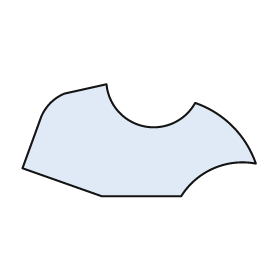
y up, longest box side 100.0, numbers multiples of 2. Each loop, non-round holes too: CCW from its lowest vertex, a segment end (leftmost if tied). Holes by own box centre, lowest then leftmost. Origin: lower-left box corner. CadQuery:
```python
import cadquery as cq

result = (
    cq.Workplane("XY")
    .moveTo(34.0, 0.0)
    .lineTo(68.0, 0.0)
    .threePointArc((82.0, 12.0), (100.0, 14.0))
    .threePointArc((90.0, 30.0), (74.0, 40.0))
    .threePointArc((52.0, 30.0), (36.0, 48.0))
    .lineTo(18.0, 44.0)
    .threePointArc((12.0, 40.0), (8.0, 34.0))
    .lineTo(0.0, 12.0)
    .close()
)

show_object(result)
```